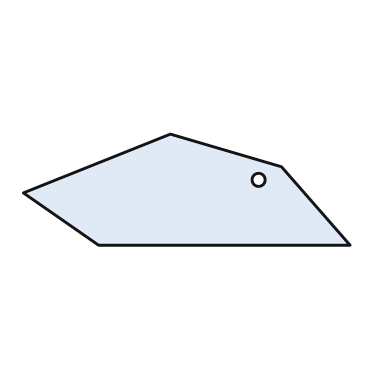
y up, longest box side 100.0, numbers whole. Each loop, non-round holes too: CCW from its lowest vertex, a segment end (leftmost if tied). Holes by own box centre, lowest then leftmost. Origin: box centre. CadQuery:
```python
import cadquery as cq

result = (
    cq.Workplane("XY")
    .moveTo(-27.0, -17.0)
    .lineTo(50.0, -17.0)
    .lineTo(29.0, 7.0)
    .lineTo(-5.0, 17.0)
    .lineTo(-50.0, -1.0)
    .close()
    .moveTo(22.0, 3.0)
    .circle(2.0)
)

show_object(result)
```